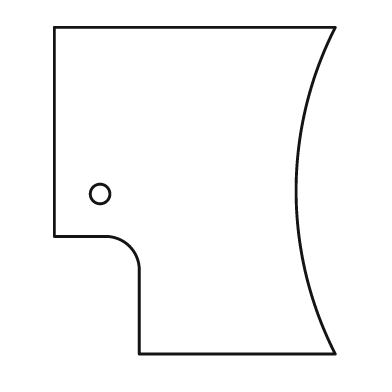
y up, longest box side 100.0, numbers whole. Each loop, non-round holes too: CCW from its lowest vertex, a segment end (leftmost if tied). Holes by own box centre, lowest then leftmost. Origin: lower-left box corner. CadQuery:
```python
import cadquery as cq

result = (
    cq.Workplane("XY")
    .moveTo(26.0, 0.0)
    .lineTo(86.0, 0.0)
    .threePointArc((74.0, 50.0), (86.0, 100.0))
    .lineTo(0.0, 100.0)
    .lineTo(0.0, 36.0)
    .lineTo(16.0, 36.0)
    .threePointArc((23.0, 33.0), (26.0, 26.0))
    .close()
    .moveTo(14.0, 49.0)
    .circle(3.0)
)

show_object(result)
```